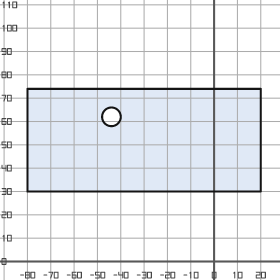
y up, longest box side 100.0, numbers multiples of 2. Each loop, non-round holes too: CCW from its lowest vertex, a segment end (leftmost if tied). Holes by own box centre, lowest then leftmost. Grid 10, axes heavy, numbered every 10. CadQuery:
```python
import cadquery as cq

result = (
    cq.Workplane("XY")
    .moveTo(-80.0, 30.0)
    .lineTo(20.0, 30.0)
    .lineTo(20.0, 74.0)
    .lineTo(-80.0, 74.0)
    .close()
    .moveTo(-44.0, 62.0)
    .circle(4.0)
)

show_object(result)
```